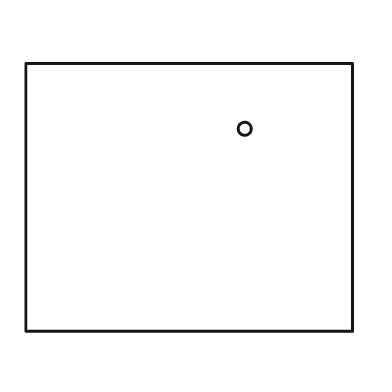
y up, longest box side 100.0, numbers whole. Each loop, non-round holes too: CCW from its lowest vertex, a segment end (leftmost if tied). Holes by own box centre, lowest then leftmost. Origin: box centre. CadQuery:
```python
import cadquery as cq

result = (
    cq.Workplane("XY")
    .moveTo(-50.0, -41.0)
    .lineTo(50.0, -41.0)
    .lineTo(50.0, 41.0)
    .lineTo(-50.0, 41.0)
    .close()
    .moveTo(17.0, 21.0)
    .circle(2.0)
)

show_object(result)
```